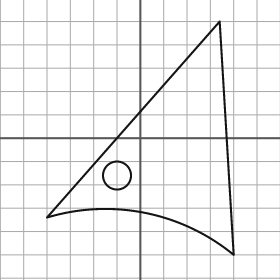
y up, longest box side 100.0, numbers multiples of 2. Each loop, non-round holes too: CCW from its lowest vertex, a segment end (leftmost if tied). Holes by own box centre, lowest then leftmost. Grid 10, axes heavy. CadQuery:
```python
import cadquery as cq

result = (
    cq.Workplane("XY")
    .moveTo(40.0, -50.0)
    .lineTo(34.0, 50.0)
    .lineTo(-40.0, -34.0)
    .threePointArc((2.0, -32.0), (40.0, -50.0))
    .close()
    .moveTo(-10.0, -16.0)
    .circle(6.0)
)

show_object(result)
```